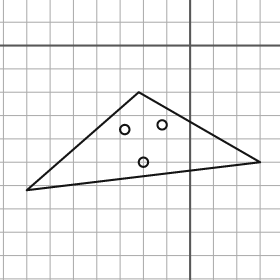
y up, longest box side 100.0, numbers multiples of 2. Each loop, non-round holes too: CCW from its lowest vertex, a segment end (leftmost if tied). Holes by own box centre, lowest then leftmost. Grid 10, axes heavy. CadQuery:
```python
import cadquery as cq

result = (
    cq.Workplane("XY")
    .moveTo(-70.0, -62.0)
    .lineTo(30.0, -50.0)
    .lineTo(-22.0, -20.0)
    .close()
    .moveTo(-20.0, -50.0)
    .circle(2.0)
    .moveTo(-28.0, -36.0)
    .circle(2.0)
    .moveTo(-12.0, -34.0)
    .circle(2.0)
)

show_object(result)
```